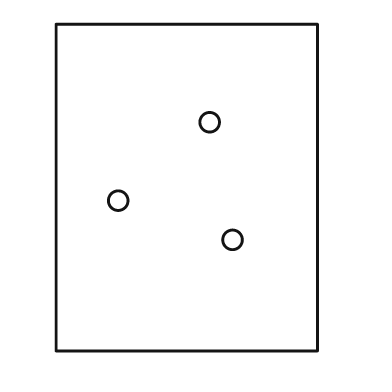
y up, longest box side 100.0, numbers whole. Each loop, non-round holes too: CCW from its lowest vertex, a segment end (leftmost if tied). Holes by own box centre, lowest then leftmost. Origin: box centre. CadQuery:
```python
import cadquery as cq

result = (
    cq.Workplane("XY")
    .moveTo(-40.0, -50.0)
    .lineTo(40.0, -50.0)
    .lineTo(40.0, 50.0)
    .lineTo(-40.0, 50.0)
    .close()
    .moveTo(14.0, -16.0)
    .circle(3.0)
    .moveTo(-21.0, -4.0)
    .circle(3.0)
    .moveTo(7.0, 20.0)
    .circle(3.0)
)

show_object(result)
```